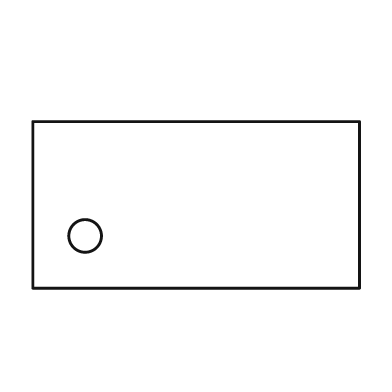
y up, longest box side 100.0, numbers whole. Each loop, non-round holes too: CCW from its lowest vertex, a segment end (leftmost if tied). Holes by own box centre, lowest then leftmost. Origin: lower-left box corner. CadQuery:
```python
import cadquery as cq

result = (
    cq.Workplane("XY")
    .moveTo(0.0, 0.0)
    .lineTo(100.0, 0.0)
    .lineTo(100.0, 51.0)
    .lineTo(0.0, 51.0)
    .close()
    .moveTo(16.0, 16.0)
    .circle(5.0)
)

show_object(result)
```